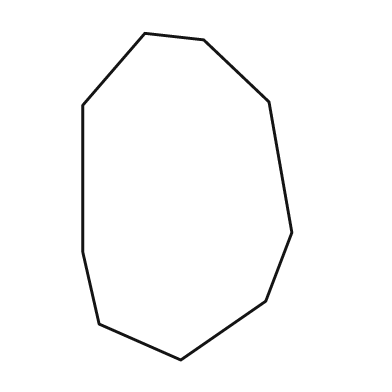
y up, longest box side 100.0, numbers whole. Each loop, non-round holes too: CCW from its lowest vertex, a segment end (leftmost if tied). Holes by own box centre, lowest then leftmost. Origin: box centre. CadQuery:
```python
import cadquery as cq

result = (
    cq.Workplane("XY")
    .moveTo(-2.0, -50.0)
    .lineTo(24.0, -32.0)
    .lineTo(32.0, -11.0)
    .lineTo(25.0, 29.0)
    .lineTo(5.0, 48.0)
    .lineTo(-13.0, 50.0)
    .lineTo(-32.0, 28.0)
    .lineTo(-32.0, -17.0)
    .lineTo(-27.0, -39.0)
    .close()
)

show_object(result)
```